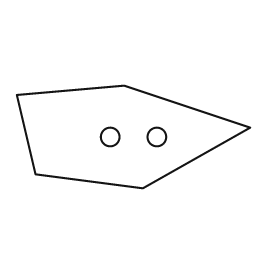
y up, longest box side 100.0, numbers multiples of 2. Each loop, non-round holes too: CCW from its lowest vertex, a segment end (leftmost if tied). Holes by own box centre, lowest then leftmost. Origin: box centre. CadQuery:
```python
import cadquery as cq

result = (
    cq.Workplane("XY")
    .moveTo(4.0, -22.0)
    .lineTo(50.0, 4.0)
    .lineTo(-4.0, 22.0)
    .lineTo(-50.0, 18.0)
    .lineTo(-42.0, -16.0)
    .close()
    .moveTo(-10.0, 0.0)
    .circle(4.0)
    .moveTo(10.0, 0.0)
    .circle(4.0)
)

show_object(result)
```